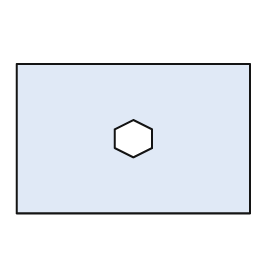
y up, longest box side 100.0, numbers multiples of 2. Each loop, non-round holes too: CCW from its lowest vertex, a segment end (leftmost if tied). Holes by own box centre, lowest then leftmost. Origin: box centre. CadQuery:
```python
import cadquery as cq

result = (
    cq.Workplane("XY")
    .moveTo(-50.0, -32.0)
    .lineTo(50.0, -32.0)
    .lineTo(50.0, 32.0)
    .lineTo(-50.0, 32.0)
    .close()
    .moveTo(0.0, -8.0)
    .lineTo(8.0, -4.0)
    .lineTo(8.0, 4.0)
    .lineTo(0.0, 8.0)
    .lineTo(-8.0, 4.0)
    .lineTo(-8.0, -4.0)
    .close()
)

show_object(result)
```